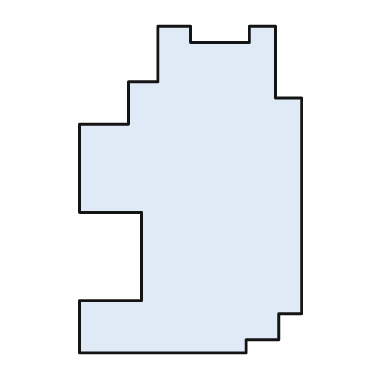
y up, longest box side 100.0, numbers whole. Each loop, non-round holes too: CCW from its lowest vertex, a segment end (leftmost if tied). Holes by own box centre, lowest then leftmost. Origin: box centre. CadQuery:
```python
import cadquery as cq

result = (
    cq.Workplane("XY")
    .moveTo(-34.0, -50.0)
    .lineTo(17.0, -50.0)
    .lineTo(17.0, -46.0)
    .lineTo(27.0, -46.0)
    .lineTo(27.0, -38.0)
    .lineTo(34.0, -38.0)
    .lineTo(34.0, 28.0)
    .lineTo(26.0, 28.0)
    .lineTo(26.0, 50.0)
    .lineTo(18.0, 50.0)
    .lineTo(18.0, 45.0)
    .lineTo(0.0, 45.0)
    .lineTo(0.0, 50.0)
    .lineTo(-10.0, 50.0)
    .lineTo(-10.0, 33.0)
    .lineTo(-19.0, 33.0)
    .lineTo(-19.0, 20.0)
    .lineTo(-34.0, 20.0)
    .lineTo(-34.0, -7.0)
    .lineTo(-15.0, -7.0)
    .lineTo(-15.0, -34.0)
    .lineTo(-34.0, -34.0)
    .close()
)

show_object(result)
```